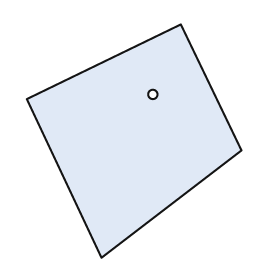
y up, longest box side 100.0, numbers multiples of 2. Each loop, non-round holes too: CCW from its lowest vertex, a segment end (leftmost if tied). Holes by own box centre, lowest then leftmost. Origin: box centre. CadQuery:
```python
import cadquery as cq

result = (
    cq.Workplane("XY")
    .moveTo(-14.0, -50.0)
    .lineTo(46.0, -4.0)
    .lineTo(20.0, 50.0)
    .lineTo(-46.0, 18.0)
    .close()
    .moveTo(8.0, 20.0)
    .circle(2.0)
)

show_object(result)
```